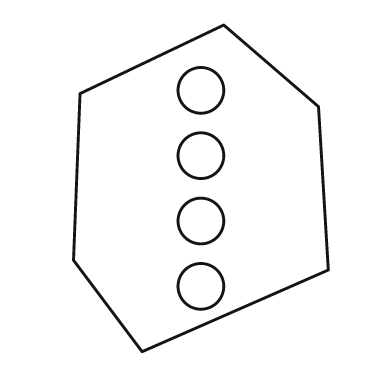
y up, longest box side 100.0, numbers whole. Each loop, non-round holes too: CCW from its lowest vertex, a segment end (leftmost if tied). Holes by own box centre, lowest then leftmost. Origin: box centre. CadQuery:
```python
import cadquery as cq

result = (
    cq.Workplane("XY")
    .moveTo(-18.0, -50.0)
    .lineTo(39.0, -25.0)
    .lineTo(36.0, 25.0)
    .lineTo(7.0, 50.0)
    .lineTo(-37.0, 29.0)
    .lineTo(-39.0, -22.0)
    .close()
    .moveTo(0.0, -30.0)
    .circle(7.0)
    .moveTo(0.0, -10.0)
    .circle(7.0)
    .moveTo(0.0, 10.0)
    .circle(7.0)
    .moveTo(0.0, 30.0)
    .circle(7.0)
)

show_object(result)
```